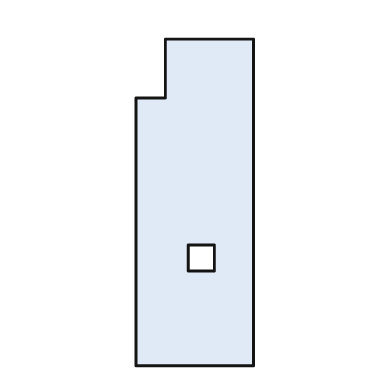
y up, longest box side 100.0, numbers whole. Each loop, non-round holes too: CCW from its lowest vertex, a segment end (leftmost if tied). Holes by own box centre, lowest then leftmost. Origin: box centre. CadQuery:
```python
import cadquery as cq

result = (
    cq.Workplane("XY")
    .moveTo(-18.0, -50.0)
    .lineTo(18.0, -50.0)
    .lineTo(18.0, 50.0)
    .lineTo(-9.0, 50.0)
    .lineTo(-9.0, 32.0)
    .lineTo(-18.0, 32.0)
    .close()
    .moveTo(-2.0, -21.0)
    .lineTo(6.0, -21.0)
    .lineTo(6.0, -13.0)
    .lineTo(-2.0, -13.0)
    .close()
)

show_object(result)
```